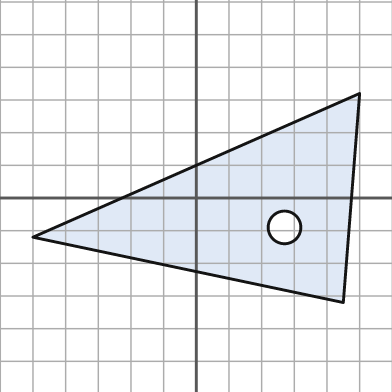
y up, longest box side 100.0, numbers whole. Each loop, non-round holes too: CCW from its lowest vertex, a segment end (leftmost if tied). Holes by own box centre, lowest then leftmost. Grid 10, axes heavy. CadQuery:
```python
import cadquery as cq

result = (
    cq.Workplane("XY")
    .moveTo(45.0, -32.0)
    .lineTo(50.0, 32.0)
    .lineTo(-50.0, -12.0)
    .close()
    .moveTo(27.0, -9.0)
    .circle(5.0)
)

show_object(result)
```